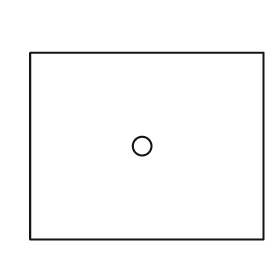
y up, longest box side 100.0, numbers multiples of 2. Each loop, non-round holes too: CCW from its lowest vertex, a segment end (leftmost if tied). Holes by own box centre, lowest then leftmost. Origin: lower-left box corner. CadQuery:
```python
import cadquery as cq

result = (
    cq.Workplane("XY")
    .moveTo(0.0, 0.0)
    .lineTo(100.0, 0.0)
    .lineTo(100.0, 80.0)
    .lineTo(0.0, 80.0)
    .close()
    .moveTo(48.0, 40.0)
    .circle(4.0)
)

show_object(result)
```